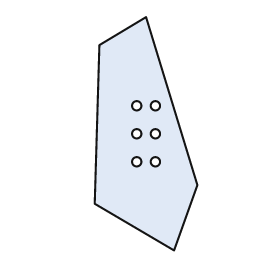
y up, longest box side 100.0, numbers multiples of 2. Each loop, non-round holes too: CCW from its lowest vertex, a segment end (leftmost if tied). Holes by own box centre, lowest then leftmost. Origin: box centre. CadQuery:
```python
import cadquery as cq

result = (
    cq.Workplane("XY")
    .moveTo(12.0, -50.0)
    .lineTo(22.0, -22.0)
    .lineTo(0.0, 50.0)
    .lineTo(-20.0, 38.0)
    .lineTo(-22.0, -30.0)
    .close()
    .moveTo(-4.0, -12.0)
    .circle(2.0)
    .moveTo(4.0, -12.0)
    .circle(2.0)
    .moveTo(-4.0, 0.0)
    .circle(2.0)
    .moveTo(4.0, 0.0)
    .circle(2.0)
    .moveTo(-4.0, 12.0)
    .circle(2.0)
    .moveTo(4.0, 12.0)
    .circle(2.0)
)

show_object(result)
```